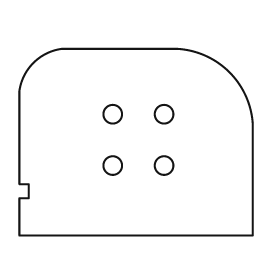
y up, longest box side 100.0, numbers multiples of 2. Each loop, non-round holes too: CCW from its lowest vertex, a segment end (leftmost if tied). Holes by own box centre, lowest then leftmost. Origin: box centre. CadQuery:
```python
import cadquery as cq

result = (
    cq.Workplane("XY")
    .moveTo(-50.0, -40.0)
    .lineTo(50.0, -40.0)
    .lineTo(50.0, 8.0)
    .threePointArc((40.0, 30.0), (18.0, 40.0))
    .lineTo(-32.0, 40.0)
    .threePointArc((-44.0, 34.0), (-50.0, 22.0))
    .lineTo(-50.0, -18.0)
    .lineTo(-46.0, -18.0)
    .lineTo(-46.0, -24.0)
    .lineTo(-50.0, -24.0)
    .close()
    .moveTo(-10.0, -10.0)
    .circle(4.0)
    .moveTo(12.0, -10.0)
    .circle(4.0)
    .moveTo(-10.0, 12.0)
    .circle(4.0)
    .moveTo(12.0, 12.0)
    .circle(4.0)
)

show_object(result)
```